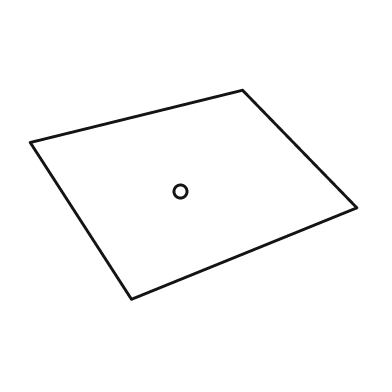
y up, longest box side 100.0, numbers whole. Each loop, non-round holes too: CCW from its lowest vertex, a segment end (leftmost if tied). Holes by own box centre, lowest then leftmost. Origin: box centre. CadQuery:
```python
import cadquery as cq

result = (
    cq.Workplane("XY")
    .moveTo(-19.0, -32.0)
    .lineTo(50.0, -4.0)
    .lineTo(15.0, 32.0)
    .lineTo(-50.0, 16.0)
    .close()
    .moveTo(-4.0, 1.0)
    .circle(2.0)
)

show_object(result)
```